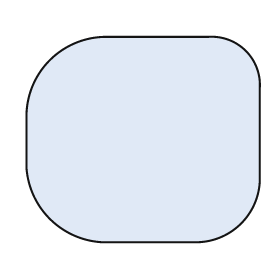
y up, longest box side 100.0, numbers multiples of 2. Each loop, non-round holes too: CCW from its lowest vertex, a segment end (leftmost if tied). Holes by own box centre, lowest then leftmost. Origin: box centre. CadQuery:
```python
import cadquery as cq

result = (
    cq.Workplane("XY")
    .moveTo(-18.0, -44.0)
    .lineTo(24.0, -44.0)
    .threePointArc((42.0, -36.0), (50.0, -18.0))
    .lineTo(50.0, 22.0)
    .threePointArc((44.0, 38.0), (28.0, 44.0))
    .lineTo(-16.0, 44.0)
    .threePointArc((-40.0, 34.0), (-50.0, 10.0))
    .lineTo(-50.0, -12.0)
    .threePointArc((-40.0, -34.0), (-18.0, -44.0))
    .close()
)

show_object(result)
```